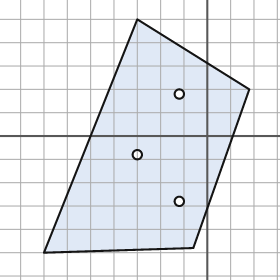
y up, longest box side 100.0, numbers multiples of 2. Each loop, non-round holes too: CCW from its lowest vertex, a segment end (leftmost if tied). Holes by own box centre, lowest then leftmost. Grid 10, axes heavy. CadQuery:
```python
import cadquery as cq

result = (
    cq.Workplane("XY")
    .moveTo(-70.0, -50.0)
    .lineTo(-6.0, -48.0)
    .lineTo(18.0, 20.0)
    .lineTo(-30.0, 50.0)
    .close()
    .moveTo(-12.0, -28.0)
    .circle(2.0)
    .moveTo(-30.0, -8.0)
    .circle(2.0)
    .moveTo(-12.0, 18.0)
    .circle(2.0)
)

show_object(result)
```